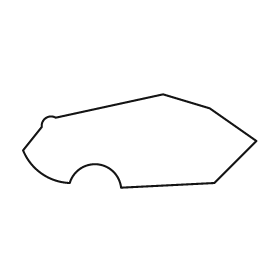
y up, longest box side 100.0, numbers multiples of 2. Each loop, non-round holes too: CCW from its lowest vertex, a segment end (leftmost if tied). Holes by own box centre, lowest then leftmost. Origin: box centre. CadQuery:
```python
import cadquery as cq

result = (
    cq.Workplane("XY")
    .moveTo(-8.0, -20.0)
    .lineTo(32.0, -18.0)
    .lineTo(50.0, 0.0)
    .lineTo(30.0, 14.0)
    .lineTo(10.0, 20.0)
    .lineTo(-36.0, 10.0)
    .threePointArc((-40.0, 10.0), (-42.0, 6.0))
    .lineTo(-50.0, -4.0)
    .threePointArc((-42.0, -14.0), (-30.0, -18.0))
    .threePointArc((-18.0, -10.0), (-8.0, -20.0))
    .close()
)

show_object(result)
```